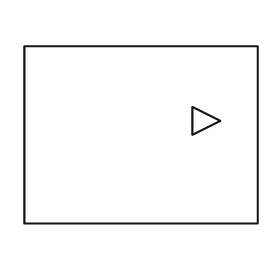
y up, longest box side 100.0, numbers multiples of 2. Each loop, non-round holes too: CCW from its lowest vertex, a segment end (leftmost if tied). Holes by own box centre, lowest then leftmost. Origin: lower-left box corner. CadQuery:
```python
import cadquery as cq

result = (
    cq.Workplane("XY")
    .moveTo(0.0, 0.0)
    .lineTo(100.0, 0.0)
    .lineTo(100.0, 76.0)
    .lineTo(0.0, 76.0)
    .close()
    .moveTo(72.0, 38.0)
    .lineTo(84.0, 44.0)
    .lineTo(72.0, 50.0)
    .close()
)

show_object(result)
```